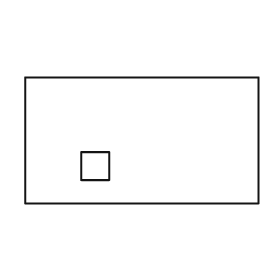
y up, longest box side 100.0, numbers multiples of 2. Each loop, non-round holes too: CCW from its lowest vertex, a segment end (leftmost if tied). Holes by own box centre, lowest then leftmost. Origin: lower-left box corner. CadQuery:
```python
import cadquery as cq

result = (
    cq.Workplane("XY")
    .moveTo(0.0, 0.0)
    .lineTo(100.0, 0.0)
    .lineTo(100.0, 54.0)
    .lineTo(0.0, 54.0)
    .close()
    .moveTo(24.0, 10.0)
    .lineTo(36.0, 10.0)
    .lineTo(36.0, 22.0)
    .lineTo(24.0, 22.0)
    .close()
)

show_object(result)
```